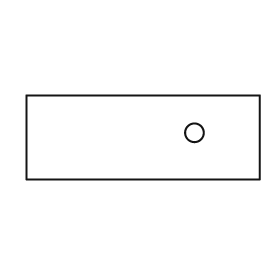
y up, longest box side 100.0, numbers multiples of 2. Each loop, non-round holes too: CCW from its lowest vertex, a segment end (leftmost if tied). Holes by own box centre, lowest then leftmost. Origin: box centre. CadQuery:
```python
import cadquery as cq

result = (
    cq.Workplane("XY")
    .moveTo(-50.0, -18.0)
    .lineTo(50.0, -18.0)
    .lineTo(50.0, 18.0)
    .lineTo(-50.0, 18.0)
    .close()
    .moveTo(22.0, 2.0)
    .circle(4.0)
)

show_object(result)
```